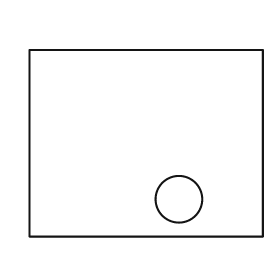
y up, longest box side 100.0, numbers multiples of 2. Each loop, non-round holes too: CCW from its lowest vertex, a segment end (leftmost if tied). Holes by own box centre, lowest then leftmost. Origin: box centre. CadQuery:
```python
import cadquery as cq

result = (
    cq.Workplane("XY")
    .moveTo(-50.0, -40.0)
    .lineTo(50.0, -40.0)
    .lineTo(50.0, 40.0)
    .lineTo(-50.0, 40.0)
    .close()
    .moveTo(14.0, -24.0)
    .circle(10.0)
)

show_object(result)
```